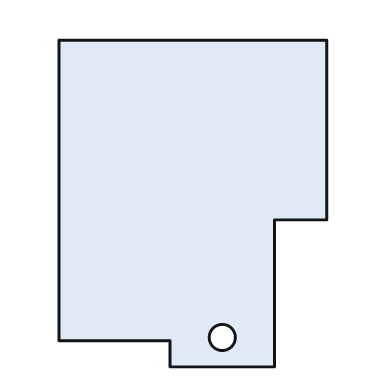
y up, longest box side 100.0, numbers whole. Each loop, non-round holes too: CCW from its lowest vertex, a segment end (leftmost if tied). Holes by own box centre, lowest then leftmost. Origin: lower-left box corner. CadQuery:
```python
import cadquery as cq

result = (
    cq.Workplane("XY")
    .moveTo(34.0, 0.0)
    .lineTo(66.0, 0.0)
    .lineTo(66.0, 45.0)
    .lineTo(82.0, 45.0)
    .lineTo(82.0, 100.0)
    .lineTo(0.0, 100.0)
    .lineTo(0.0, 8.0)
    .lineTo(34.0, 8.0)
    .close()
    .moveTo(50.0, 9.0)
    .circle(4.0)
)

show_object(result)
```